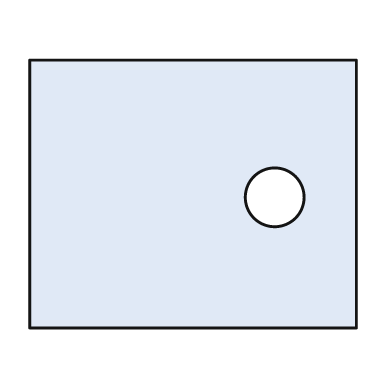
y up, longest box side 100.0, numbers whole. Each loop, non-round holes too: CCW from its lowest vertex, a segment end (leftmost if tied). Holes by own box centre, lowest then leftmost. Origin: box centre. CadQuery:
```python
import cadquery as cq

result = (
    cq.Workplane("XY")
    .moveTo(-50.0, -41.0)
    .lineTo(50.0, -41.0)
    .lineTo(50.0, 41.0)
    .lineTo(-50.0, 41.0)
    .close()
    .moveTo(25.0, -1.0)
    .circle(9.0)
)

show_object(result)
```